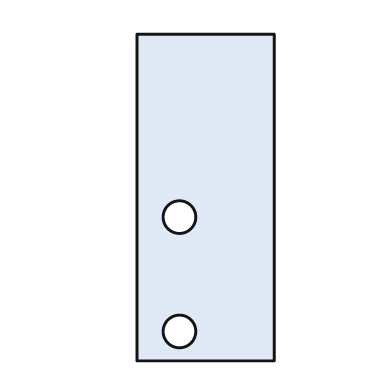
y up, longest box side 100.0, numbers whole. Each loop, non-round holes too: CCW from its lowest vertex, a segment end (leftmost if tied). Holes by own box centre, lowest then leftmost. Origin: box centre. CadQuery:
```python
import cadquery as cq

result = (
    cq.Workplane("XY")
    .moveTo(-21.0, -50.0)
    .lineTo(21.0, -50.0)
    .lineTo(21.0, 50.0)
    .lineTo(-21.0, 50.0)
    .close()
    .moveTo(-8.0, -41.0)
    .circle(5.0)
    .moveTo(-8.0, -6.0)
    .circle(5.0)
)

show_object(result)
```